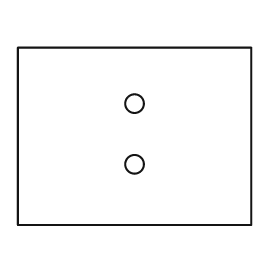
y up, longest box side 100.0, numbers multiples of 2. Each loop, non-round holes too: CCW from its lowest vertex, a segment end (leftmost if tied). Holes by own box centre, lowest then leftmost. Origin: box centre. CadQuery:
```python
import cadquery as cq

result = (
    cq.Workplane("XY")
    .moveTo(-50.0, -38.0)
    .lineTo(50.0, -38.0)
    .lineTo(50.0, 38.0)
    .lineTo(-50.0, 38.0)
    .close()
    .moveTo(0.0, -12.0)
    .circle(4.0)
    .moveTo(0.0, 14.0)
    .circle(4.0)
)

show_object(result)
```